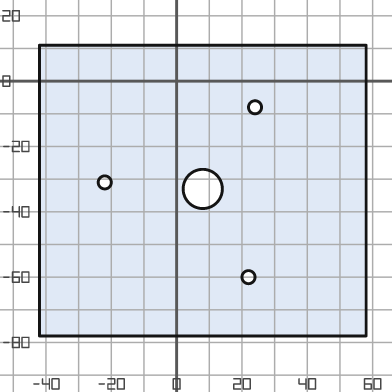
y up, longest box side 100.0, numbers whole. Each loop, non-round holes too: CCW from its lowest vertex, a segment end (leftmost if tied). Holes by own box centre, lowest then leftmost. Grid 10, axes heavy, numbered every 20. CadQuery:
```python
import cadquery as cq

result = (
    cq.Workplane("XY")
    .moveTo(-42.0, -78.0)
    .lineTo(58.0, -78.0)
    .lineTo(58.0, 11.0)
    .lineTo(-42.0, 11.0)
    .close()
    .moveTo(22.0, -60.0)
    .circle(2.0)
    .moveTo(8.0, -33.0)
    .circle(6.0)
    .moveTo(-22.0, -31.0)
    .circle(2.0)
    .moveTo(24.0, -8.0)
    .circle(2.0)
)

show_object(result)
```